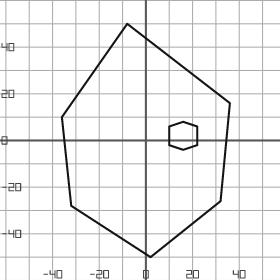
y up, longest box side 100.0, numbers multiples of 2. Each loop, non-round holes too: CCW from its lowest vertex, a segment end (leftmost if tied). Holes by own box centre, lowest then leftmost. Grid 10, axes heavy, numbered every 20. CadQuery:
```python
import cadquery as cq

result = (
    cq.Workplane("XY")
    .moveTo(2.0, -50.0)
    .lineTo(32.0, -26.0)
    .lineTo(36.0, 16.0)
    .lineTo(-8.0, 50.0)
    .lineTo(-36.0, 10.0)
    .lineTo(-32.0, -28.0)
    .close()
    .moveTo(16.0, -4.0)
    .lineTo(22.0, -2.0)
    .lineTo(22.0, 6.0)
    .lineTo(16.0, 8.0)
    .lineTo(10.0, 6.0)
    .lineTo(10.0, -2.0)
    .close()
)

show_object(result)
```